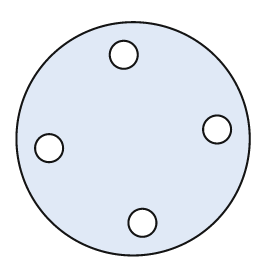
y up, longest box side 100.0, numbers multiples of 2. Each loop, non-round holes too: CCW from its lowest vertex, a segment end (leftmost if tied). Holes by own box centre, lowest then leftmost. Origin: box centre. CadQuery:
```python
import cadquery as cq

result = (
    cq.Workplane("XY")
    .moveTo(0.0, 0.0)
    .circle(50.0)
    .moveTo(4.0, -36.0)
    .circle(6.0)
    .moveTo(-36.0, -4.0)
    .circle(6.0)
    .moveTo(36.0, 4.0)
    .circle(6.0)
    .moveTo(-4.0, 36.0)
    .circle(6.0)
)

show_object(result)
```